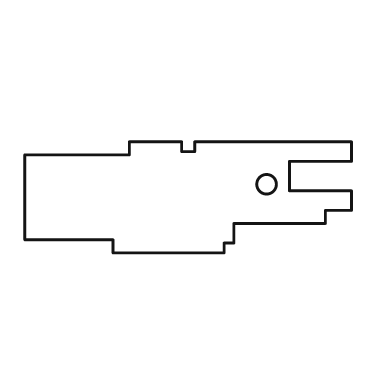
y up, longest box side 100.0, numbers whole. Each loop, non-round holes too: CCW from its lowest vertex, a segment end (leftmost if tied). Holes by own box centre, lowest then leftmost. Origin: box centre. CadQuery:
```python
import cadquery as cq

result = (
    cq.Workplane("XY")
    .moveTo(-23.0, -17.0)
    .lineTo(11.0, -17.0)
    .lineTo(11.0, -14.0)
    .lineTo(14.0, -14.0)
    .lineTo(14.0, -8.0)
    .lineTo(42.0, -8.0)
    .lineTo(42.0, -4.0)
    .lineTo(50.0, -4.0)
    .lineTo(50.0, 2.0)
    .lineTo(31.0, 2.0)
    .lineTo(31.0, 11.0)
    .lineTo(50.0, 11.0)
    .lineTo(50.0, 17.0)
    .lineTo(2.0, 17.0)
    .lineTo(2.0, 14.0)
    .lineTo(-2.0, 14.0)
    .lineTo(-2.0, 17.0)
    .lineTo(-18.0, 17.0)
    .lineTo(-18.0, 13.0)
    .lineTo(-50.0, 13.0)
    .lineTo(-50.0, -13.0)
    .lineTo(-23.0, -13.0)
    .close()
    .moveTo(24.0, 4.0)
    .circle(3.0)
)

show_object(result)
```